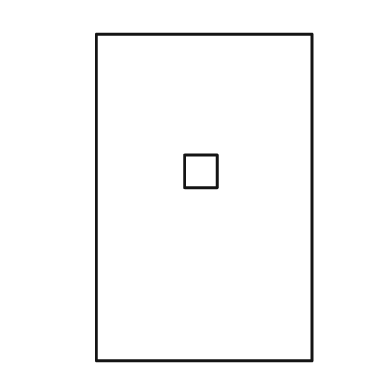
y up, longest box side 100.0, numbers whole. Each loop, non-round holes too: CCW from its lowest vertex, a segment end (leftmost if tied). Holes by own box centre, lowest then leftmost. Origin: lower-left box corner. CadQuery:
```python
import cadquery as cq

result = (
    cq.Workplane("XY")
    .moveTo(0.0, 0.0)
    .lineTo(66.0, 0.0)
    .lineTo(66.0, 100.0)
    .lineTo(0.0, 100.0)
    .close()
    .moveTo(27.0, 53.0)
    .lineTo(37.0, 53.0)
    .lineTo(37.0, 63.0)
    .lineTo(27.0, 63.0)
    .close()
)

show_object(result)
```